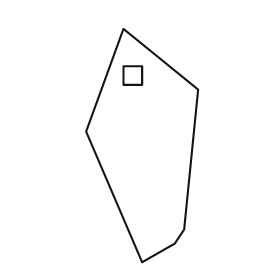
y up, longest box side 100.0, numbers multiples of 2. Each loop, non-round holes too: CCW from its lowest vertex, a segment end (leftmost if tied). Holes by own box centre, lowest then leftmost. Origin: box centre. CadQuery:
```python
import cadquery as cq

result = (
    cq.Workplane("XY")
    .moveTo(0.0, -50.0)
    .lineTo(14.0, -42.0)
    .lineTo(18.0, -36.0)
    .lineTo(24.0, 24.0)
    .lineTo(-8.0, 50.0)
    .lineTo(-24.0, 6.0)
    .close()
    .moveTo(-8.0, 26.0)
    .lineTo(0.0, 26.0)
    .lineTo(0.0, 34.0)
    .lineTo(-8.0, 34.0)
    .close()
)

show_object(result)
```